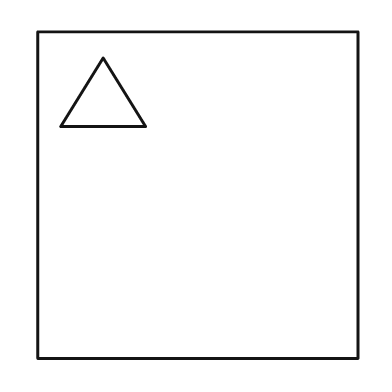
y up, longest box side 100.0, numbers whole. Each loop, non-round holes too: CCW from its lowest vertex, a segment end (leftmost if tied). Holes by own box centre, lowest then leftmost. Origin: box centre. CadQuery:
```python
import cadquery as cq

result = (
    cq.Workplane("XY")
    .moveTo(-49.0, -50.0)
    .lineTo(49.0, -50.0)
    .lineTo(49.0, 50.0)
    .lineTo(-49.0, 50.0)
    .close()
    .moveTo(-42.0, 21.0)
    .lineTo(-16.0, 21.0)
    .lineTo(-29.0, 42.0)
    .close()
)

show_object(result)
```